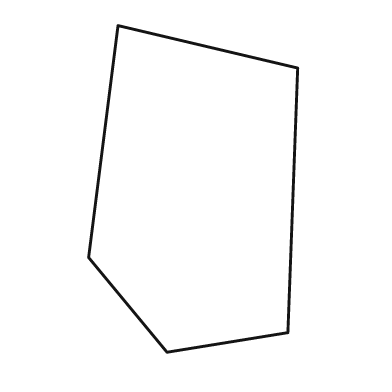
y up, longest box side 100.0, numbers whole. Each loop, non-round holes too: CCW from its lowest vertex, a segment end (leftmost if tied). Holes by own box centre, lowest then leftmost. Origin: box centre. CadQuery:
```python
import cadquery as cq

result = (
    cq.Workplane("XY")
    .moveTo(-8.0, -50.0)
    .lineTo(29.0, -44.0)
    .lineTo(32.0, 37.0)
    .lineTo(-23.0, 50.0)
    .lineTo(-32.0, -21.0)
    .close()
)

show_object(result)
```